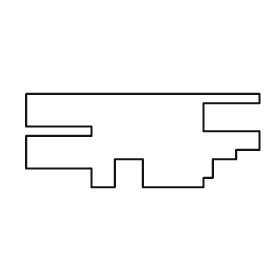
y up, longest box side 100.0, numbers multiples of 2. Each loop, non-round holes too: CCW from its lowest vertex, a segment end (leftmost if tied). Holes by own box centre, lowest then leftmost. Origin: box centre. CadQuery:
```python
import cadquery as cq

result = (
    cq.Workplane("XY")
    .moveTo(-22.0, -20.0)
    .lineTo(-12.0, -20.0)
    .lineTo(-12.0, -8.0)
    .lineTo(0.0, -8.0)
    .lineTo(0.0, -20.0)
    .lineTo(26.0, -20.0)
    .lineTo(26.0, -16.0)
    .lineTo(30.0, -16.0)
    .lineTo(30.0, -8.0)
    .lineTo(40.0, -8.0)
    .lineTo(40.0, -4.0)
    .lineTo(50.0, -4.0)
    .lineTo(50.0, 4.0)
    .lineTo(26.0, 4.0)
    .lineTo(26.0, 16.0)
    .lineTo(50.0, 16.0)
    .lineTo(50.0, 20.0)
    .lineTo(-50.0, 20.0)
    .lineTo(-50.0, 6.0)
    .lineTo(-22.0, 6.0)
    .lineTo(-22.0, 2.0)
    .lineTo(-50.0, 2.0)
    .lineTo(-50.0, -12.0)
    .lineTo(-22.0, -12.0)
    .close()
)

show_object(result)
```